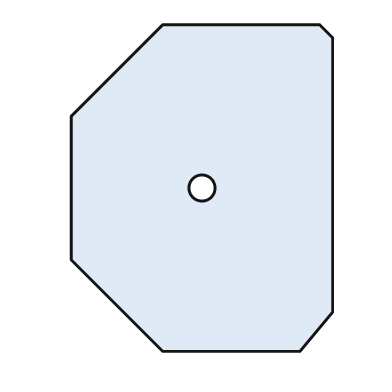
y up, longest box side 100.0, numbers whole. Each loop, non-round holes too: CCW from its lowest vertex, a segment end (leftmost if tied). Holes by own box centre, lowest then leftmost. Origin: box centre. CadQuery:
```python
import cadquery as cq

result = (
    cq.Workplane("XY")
    .moveTo(-12.0, -50.0)
    .lineTo(30.0, -50.0)
    .lineTo(40.0, -38.0)
    .lineTo(40.0, 46.0)
    .lineTo(36.0, 50.0)
    .lineTo(-12.0, 50.0)
    .lineTo(-40.0, 22.0)
    .lineTo(-40.0, -22.0)
    .close()
    .moveTo(0.0, 0.0)
    .circle(4.0)
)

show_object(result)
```